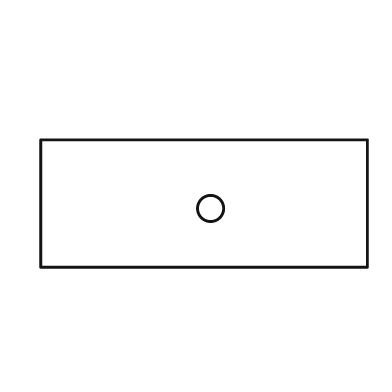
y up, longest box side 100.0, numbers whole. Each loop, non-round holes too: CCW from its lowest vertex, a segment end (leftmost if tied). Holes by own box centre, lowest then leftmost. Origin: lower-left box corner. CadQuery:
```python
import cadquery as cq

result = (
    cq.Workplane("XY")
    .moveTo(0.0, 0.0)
    .lineTo(100.0, 0.0)
    .lineTo(100.0, 39.0)
    .lineTo(0.0, 39.0)
    .close()
    .moveTo(52.0, 18.0)
    .circle(4.0)
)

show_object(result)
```